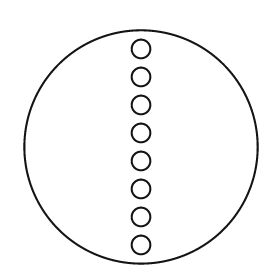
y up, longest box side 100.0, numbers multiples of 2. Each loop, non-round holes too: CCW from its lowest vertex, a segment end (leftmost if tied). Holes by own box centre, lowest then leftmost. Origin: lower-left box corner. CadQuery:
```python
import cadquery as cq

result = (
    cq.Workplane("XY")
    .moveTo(50.0, 50.0)
    .circle(50.0)
    .moveTo(50.0, 8.0)
    .circle(4.0)
    .moveTo(50.0, 20.0)
    .circle(4.0)
    .moveTo(50.0, 32.0)
    .circle(4.0)
    .moveTo(50.0, 44.0)
    .circle(4.0)
    .moveTo(50.0, 56.0)
    .circle(4.0)
    .moveTo(50.0, 68.0)
    .circle(4.0)
    .moveTo(50.0, 80.0)
    .circle(4.0)
    .moveTo(50.0, 92.0)
    .circle(4.0)
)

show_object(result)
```